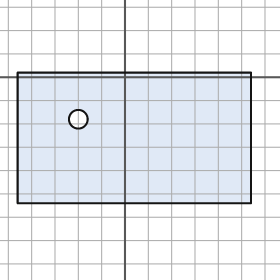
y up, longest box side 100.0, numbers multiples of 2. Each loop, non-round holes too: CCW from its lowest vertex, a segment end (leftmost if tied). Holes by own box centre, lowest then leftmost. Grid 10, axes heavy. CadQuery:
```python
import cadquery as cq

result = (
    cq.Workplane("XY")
    .moveTo(-46.0, -54.0)
    .lineTo(54.0, -54.0)
    .lineTo(54.0, 2.0)
    .lineTo(-46.0, 2.0)
    .close()
    .moveTo(-20.0, -18.0)
    .circle(4.0)
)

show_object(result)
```